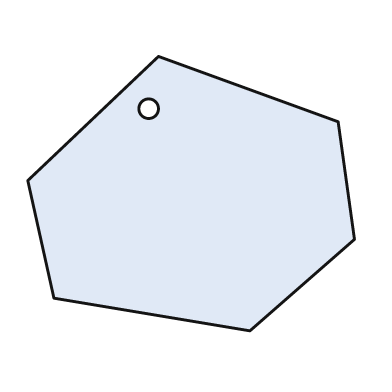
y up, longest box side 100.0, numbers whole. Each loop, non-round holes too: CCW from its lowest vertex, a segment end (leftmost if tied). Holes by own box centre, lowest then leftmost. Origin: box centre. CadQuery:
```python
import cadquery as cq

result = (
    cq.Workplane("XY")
    .moveTo(18.0, -42.0)
    .lineTo(50.0, -14.0)
    .lineTo(45.0, 22.0)
    .lineTo(-10.0, 42.0)
    .lineTo(-50.0, 4.0)
    .lineTo(-42.0, -32.0)
    .close()
    .moveTo(-13.0, 26.0)
    .circle(3.0)
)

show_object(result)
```